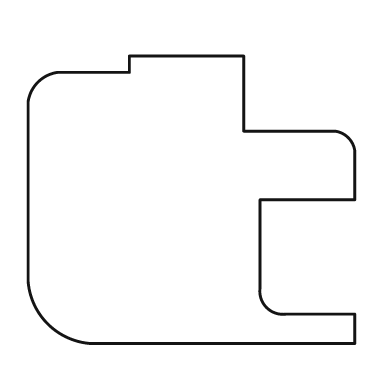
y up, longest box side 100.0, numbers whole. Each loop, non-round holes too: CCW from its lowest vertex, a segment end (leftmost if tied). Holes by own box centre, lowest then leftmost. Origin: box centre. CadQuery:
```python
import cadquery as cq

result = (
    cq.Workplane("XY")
    .moveTo(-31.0, -44.0)
    .lineTo(50.0, -44.0)
    .lineTo(50.0, -35.0)
    .lineTo(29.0, -35.0)
    .threePointArc((23.0, -33.0), (21.0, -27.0))
    .lineTo(21.0, 0.0)
    .lineTo(50.0, 0.0)
    .lineTo(50.0, 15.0)
    .threePointArc((48.0, 19.0), (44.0, 21.0))
    .lineTo(16.0, 21.0)
    .lineTo(16.0, 44.0)
    .lineTo(-19.0, 44.0)
    .lineTo(-19.0, 39.0)
    .lineTo(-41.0, 39.0)
    .threePointArc((-47.0, 36.0), (-50.0, 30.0))
    .lineTo(-50.0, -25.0)
    .threePointArc((-44.0, -38.0), (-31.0, -44.0))
    .close()
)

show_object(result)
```